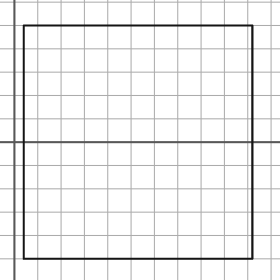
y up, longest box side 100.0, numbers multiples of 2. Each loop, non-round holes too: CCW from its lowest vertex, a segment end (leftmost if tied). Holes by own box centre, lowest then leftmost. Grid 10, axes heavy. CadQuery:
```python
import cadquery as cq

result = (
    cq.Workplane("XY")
    .moveTo(4.0, -50.0)
    .lineTo(102.0, -50.0)
    .lineTo(102.0, 50.0)
    .lineTo(4.0, 50.0)
    .close()
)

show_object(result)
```